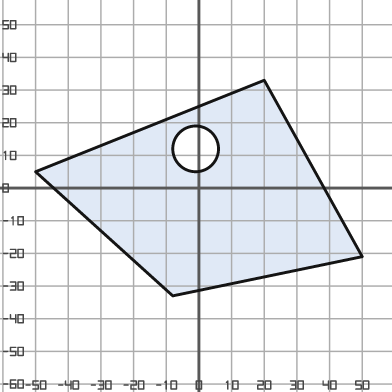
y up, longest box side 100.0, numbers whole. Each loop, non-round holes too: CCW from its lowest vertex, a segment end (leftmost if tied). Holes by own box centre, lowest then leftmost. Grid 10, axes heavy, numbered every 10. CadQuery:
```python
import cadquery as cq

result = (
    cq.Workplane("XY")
    .moveTo(-8.0, -33.0)
    .lineTo(50.0, -21.0)
    .lineTo(20.0, 33.0)
    .lineTo(-50.0, 5.0)
    .close()
    .moveTo(-1.0, 12.0)
    .circle(7.0)
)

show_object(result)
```